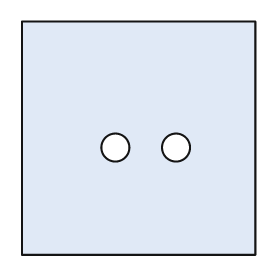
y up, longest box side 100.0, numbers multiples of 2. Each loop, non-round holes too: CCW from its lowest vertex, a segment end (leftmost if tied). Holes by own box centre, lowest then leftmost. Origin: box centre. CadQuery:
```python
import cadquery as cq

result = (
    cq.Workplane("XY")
    .moveTo(-50.0, -50.0)
    .lineTo(50.0, -50.0)
    .lineTo(50.0, 50.0)
    .lineTo(-50.0, 50.0)
    .close()
    .moveTo(-10.0, -4.0)
    .circle(6.0)
    .moveTo(16.0, -4.0)
    .circle(6.0)
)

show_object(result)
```